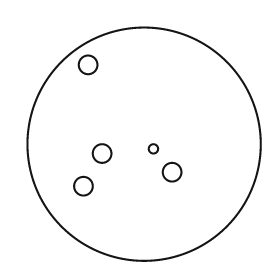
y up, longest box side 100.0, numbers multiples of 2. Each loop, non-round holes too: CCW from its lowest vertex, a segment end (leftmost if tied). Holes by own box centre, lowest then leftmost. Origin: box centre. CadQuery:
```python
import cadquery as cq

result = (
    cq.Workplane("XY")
    .moveTo(0.0, 0.0)
    .circle(50.0)
    .moveTo(-26.0, -18.0)
    .circle(4.0)
    .moveTo(12.0, -12.0)
    .circle(4.0)
    .moveTo(-18.0, -4.0)
    .circle(4.0)
    .moveTo(4.0, -2.0)
    .circle(2.0)
    .moveTo(-24.0, 34.0)
    .circle(4.0)
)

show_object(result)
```